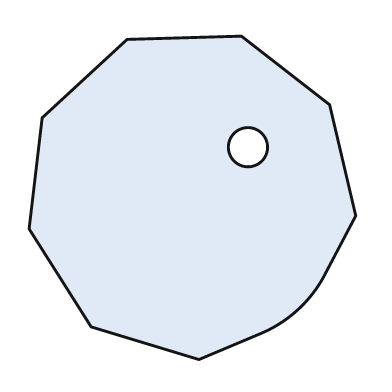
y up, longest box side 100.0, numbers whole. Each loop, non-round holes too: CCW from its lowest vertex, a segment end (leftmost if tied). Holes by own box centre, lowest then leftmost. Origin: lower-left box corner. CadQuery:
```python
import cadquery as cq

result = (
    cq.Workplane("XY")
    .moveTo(52.0, 0.0)
    .lineTo(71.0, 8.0)
    .threePointArc((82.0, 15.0), (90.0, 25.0))
    .lineTo(100.0, 44.0)
    .lineTo(92.0, 78.0)
    .lineTo(65.0, 99.0)
    .lineTo(30.0, 98.0)
    .lineTo(4.0, 74.0)
    .lineTo(0.0, 40.0)
    .lineTo(19.0, 10.0)
    .close()
    .moveTo(67.0, 65.0)
    .circle(6.0)
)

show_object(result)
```